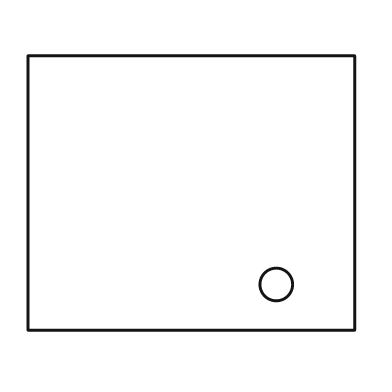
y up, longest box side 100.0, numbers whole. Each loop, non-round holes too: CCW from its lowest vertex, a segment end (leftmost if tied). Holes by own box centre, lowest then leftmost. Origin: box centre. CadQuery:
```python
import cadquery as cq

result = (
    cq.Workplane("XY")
    .moveTo(-50.0, -42.0)
    .lineTo(50.0, -42.0)
    .lineTo(50.0, 42.0)
    .lineTo(-50.0, 42.0)
    .close()
    .moveTo(26.0, -28.0)
    .circle(5.0)
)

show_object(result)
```